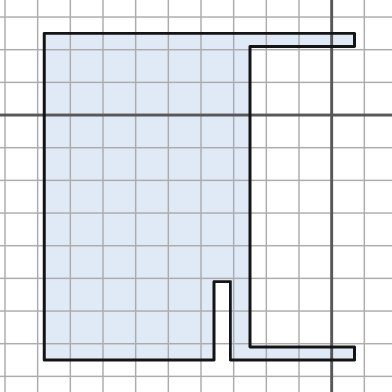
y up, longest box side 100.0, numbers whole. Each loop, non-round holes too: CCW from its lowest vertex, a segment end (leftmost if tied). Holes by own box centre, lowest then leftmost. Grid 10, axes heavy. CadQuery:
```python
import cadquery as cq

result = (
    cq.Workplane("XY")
    .moveTo(-88.0, -75.0)
    .lineTo(-36.0, -75.0)
    .lineTo(-36.0, -51.0)
    .lineTo(-31.0, -51.0)
    .lineTo(-31.0, -75.0)
    .lineTo(7.0, -75.0)
    .lineTo(7.0, -71.0)
    .lineTo(-25.0, -71.0)
    .lineTo(-25.0, 21.0)
    .lineTo(7.0, 21.0)
    .lineTo(7.0, 25.0)
    .lineTo(-88.0, 25.0)
    .close()
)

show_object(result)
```